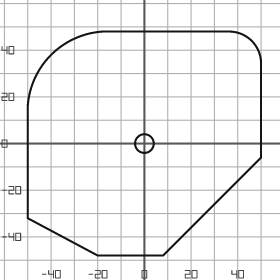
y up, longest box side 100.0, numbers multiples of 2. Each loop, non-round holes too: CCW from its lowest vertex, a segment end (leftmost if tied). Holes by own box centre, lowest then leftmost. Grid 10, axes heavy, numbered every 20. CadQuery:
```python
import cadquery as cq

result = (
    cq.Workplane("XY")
    .moveTo(-20.0, -48.0)
    .lineTo(8.0, -48.0)
    .lineTo(50.0, -6.0)
    .lineTo(50.0, 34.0)
    .threePointArc((46.0, 44.0), (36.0, 48.0))
    .lineTo(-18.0, 48.0)
    .threePointArc((-40.0, 38.0), (-50.0, 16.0))
    .lineTo(-50.0, -32.0)
    .close()
    .moveTo(0.0, 0.0)
    .circle(4.0)
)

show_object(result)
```